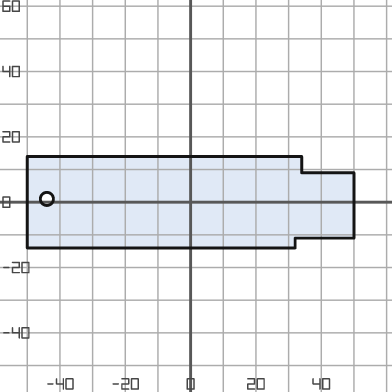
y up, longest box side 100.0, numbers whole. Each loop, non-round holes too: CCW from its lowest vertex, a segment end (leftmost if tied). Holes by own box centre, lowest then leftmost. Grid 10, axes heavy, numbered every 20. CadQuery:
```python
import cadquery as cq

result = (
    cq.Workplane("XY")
    .moveTo(-50.0, -14.0)
    .lineTo(32.0, -14.0)
    .lineTo(32.0, -11.0)
    .lineTo(50.0, -11.0)
    .lineTo(50.0, 9.0)
    .lineTo(34.0, 9.0)
    .lineTo(34.0, 14.0)
    .lineTo(-50.0, 14.0)
    .close()
    .moveTo(-44.0, 1.0)
    .circle(2.0)
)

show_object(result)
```